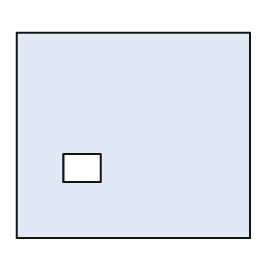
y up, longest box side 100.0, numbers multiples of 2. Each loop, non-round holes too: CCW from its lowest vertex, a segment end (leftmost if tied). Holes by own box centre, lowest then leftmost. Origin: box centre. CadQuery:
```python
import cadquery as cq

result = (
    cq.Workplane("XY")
    .moveTo(-50.0, -44.0)
    .lineTo(50.0, -44.0)
    .lineTo(50.0, 44.0)
    .lineTo(-50.0, 44.0)
    .close()
    .moveTo(-30.0, -20.0)
    .lineTo(-14.0, -20.0)
    .lineTo(-14.0, -8.0)
    .lineTo(-30.0, -8.0)
    .close()
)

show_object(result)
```